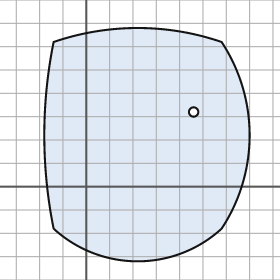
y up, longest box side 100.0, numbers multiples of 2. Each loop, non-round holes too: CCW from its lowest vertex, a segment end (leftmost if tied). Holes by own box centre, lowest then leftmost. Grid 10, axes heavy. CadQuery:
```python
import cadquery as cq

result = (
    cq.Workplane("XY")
    .moveTo(-14.0, -18.0)
    .threePointArc((22.0, -32.0), (58.0, -18.0))
    .threePointArc((70.0, 22.0), (58.0, 62.0))
    .threePointArc((22.0, 68.0), (-14.0, 62.0))
    .threePointArc((-18.0, 22.0), (-14.0, -18.0))
    .close()
    .moveTo(46.0, 32.0)
    .circle(2.0)
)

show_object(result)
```